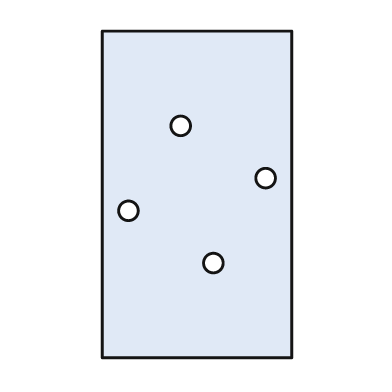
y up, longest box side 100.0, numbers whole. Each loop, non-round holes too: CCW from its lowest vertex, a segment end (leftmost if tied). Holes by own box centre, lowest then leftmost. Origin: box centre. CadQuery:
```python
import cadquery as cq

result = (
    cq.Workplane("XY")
    .moveTo(-29.0, -50.0)
    .lineTo(29.0, -50.0)
    .lineTo(29.0, 50.0)
    .lineTo(-29.0, 50.0)
    .close()
    .moveTo(5.0, -21.0)
    .circle(3.0)
    .moveTo(-21.0, -5.0)
    .circle(3.0)
    .moveTo(21.0, 5.0)
    .circle(3.0)
    .moveTo(-5.0, 21.0)
    .circle(3.0)
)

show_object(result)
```